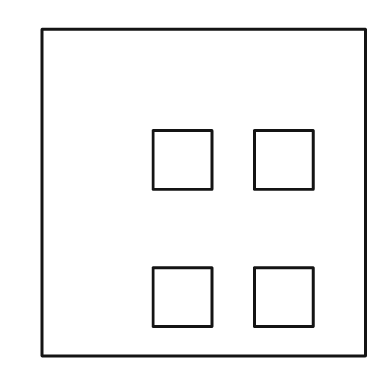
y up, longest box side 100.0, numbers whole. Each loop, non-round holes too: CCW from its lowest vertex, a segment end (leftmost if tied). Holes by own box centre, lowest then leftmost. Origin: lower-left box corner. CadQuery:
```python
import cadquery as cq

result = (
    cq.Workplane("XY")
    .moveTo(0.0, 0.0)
    .lineTo(99.0, 0.0)
    .lineTo(99.0, 100.0)
    .lineTo(0.0, 100.0)
    .close()
    .moveTo(34.0, 9.0)
    .lineTo(52.0, 9.0)
    .lineTo(52.0, 27.0)
    .lineTo(34.0, 27.0)
    .close()
    .moveTo(65.0, 9.0)
    .lineTo(83.0, 9.0)
    .lineTo(83.0, 27.0)
    .lineTo(65.0, 27.0)
    .close()
    .moveTo(34.0, 51.0)
    .lineTo(52.0, 51.0)
    .lineTo(52.0, 69.0)
    .lineTo(34.0, 69.0)
    .close()
    .moveTo(65.0, 51.0)
    .lineTo(83.0, 51.0)
    .lineTo(83.0, 69.0)
    .lineTo(65.0, 69.0)
    .close()
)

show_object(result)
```